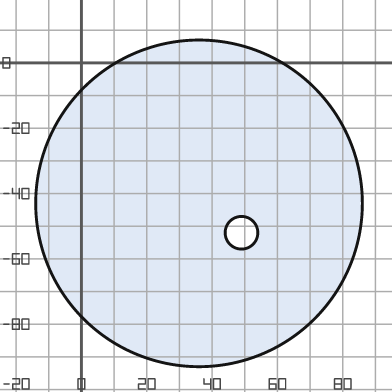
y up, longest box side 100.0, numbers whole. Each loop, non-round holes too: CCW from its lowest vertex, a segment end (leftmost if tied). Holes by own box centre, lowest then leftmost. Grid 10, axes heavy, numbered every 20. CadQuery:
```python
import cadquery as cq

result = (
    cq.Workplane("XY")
    .moveTo(36.0, -43.0)
    .circle(50.0)
    .moveTo(49.0, -52.0)
    .circle(5.0)
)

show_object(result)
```